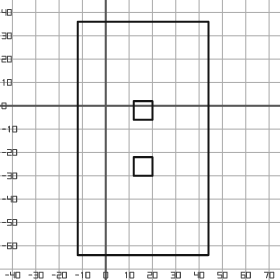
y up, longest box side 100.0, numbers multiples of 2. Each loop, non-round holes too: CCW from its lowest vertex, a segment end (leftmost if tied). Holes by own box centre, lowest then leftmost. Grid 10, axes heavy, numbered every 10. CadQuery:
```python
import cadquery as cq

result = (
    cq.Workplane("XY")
    .moveTo(-12.0, -64.0)
    .lineTo(44.0, -64.0)
    .lineTo(44.0, 36.0)
    .lineTo(-12.0, 36.0)
    .close()
    .moveTo(12.0, -30.0)
    .lineTo(20.0, -30.0)
    .lineTo(20.0, -22.0)
    .lineTo(12.0, -22.0)
    .close()
    .moveTo(12.0, -6.0)
    .lineTo(20.0, -6.0)
    .lineTo(20.0, 2.0)
    .lineTo(12.0, 2.0)
    .close()
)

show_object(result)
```